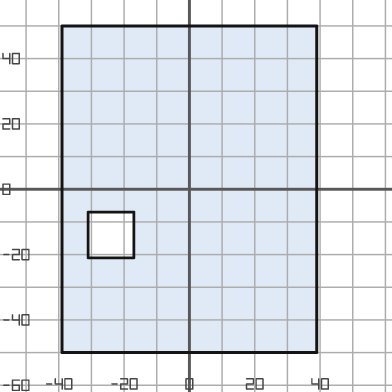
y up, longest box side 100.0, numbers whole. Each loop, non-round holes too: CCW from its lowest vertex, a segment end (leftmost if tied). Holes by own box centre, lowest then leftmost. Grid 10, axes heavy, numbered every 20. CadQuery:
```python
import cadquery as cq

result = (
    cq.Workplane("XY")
    .moveTo(-39.0, -50.0)
    .lineTo(39.0, -50.0)
    .lineTo(39.0, 50.0)
    .lineTo(-39.0, 50.0)
    .close()
    .moveTo(-31.0, -21.0)
    .lineTo(-17.0, -21.0)
    .lineTo(-17.0, -7.0)
    .lineTo(-31.0, -7.0)
    .close()
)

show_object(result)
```